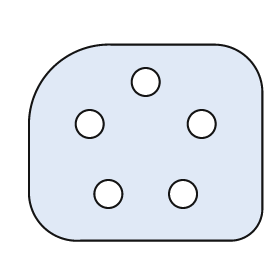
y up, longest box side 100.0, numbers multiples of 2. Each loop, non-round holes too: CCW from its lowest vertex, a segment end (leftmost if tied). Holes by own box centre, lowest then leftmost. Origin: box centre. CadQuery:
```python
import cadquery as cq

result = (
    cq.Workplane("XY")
    .moveTo(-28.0, -42.0)
    .lineTo(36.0, -42.0)
    .threePointArc((46.0, -38.0), (50.0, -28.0))
    .lineTo(50.0, 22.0)
    .threePointArc((44.0, 36.0), (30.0, 42.0))
    .lineTo(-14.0, 42.0)
    .threePointArc((-40.0, 32.0), (-50.0, 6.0))
    .lineTo(-50.0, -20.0)
    .threePointArc((-44.0, -36.0), (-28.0, -42.0))
    .close()
    .moveTo(-16.0, -22.0)
    .circle(6.0)
    .moveTo(16.0, -22.0)
    .circle(6.0)
    .moveTo(-24.0, 8.0)
    .circle(6.0)
    .moveTo(24.0, 8.0)
    .circle(6.0)
    .moveTo(0.0, 26.0)
    .circle(6.0)
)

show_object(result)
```